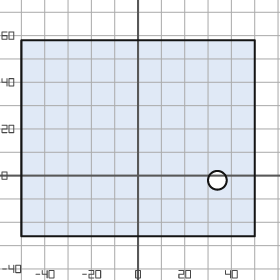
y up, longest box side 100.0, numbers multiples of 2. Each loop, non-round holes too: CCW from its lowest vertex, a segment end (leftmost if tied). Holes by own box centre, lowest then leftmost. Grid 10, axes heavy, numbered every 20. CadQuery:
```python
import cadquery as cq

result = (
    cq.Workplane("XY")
    .moveTo(-50.0, -26.0)
    .lineTo(50.0, -26.0)
    .lineTo(50.0, 58.0)
    .lineTo(-50.0, 58.0)
    .close()
    .moveTo(34.0, -2.0)
    .circle(4.0)
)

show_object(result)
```